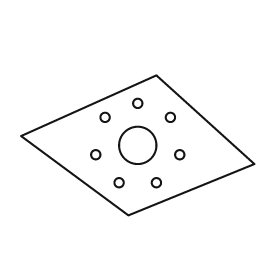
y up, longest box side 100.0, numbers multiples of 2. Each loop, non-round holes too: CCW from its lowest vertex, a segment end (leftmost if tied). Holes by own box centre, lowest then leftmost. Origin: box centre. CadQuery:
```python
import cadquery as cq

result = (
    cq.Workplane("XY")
    .moveTo(-4.0, -30.0)
    .lineTo(50.0, -8.0)
    .lineTo(8.0, 30.0)
    .lineTo(-50.0, 4.0)
    .close()
    .moveTo(-8.0, -16.0)
    .circle(2.0)
    .moveTo(8.0, -16.0)
    .circle(2.0)
    .moveTo(-18.0, -4.0)
    .circle(2.0)
    .moveTo(18.0, -4.0)
    .circle(2.0)
    .moveTo(0.0, 0.0)
    .circle(8.0)
    .moveTo(-14.0, 12.0)
    .circle(2.0)
    .moveTo(14.0, 12.0)
    .circle(2.0)
    .moveTo(0.0, 18.0)
    .circle(2.0)
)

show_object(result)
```